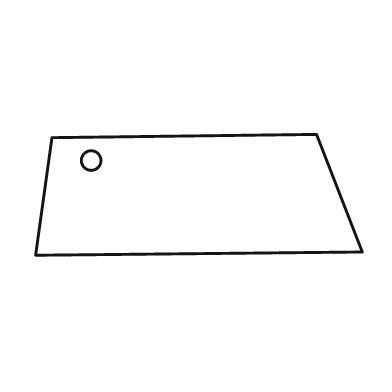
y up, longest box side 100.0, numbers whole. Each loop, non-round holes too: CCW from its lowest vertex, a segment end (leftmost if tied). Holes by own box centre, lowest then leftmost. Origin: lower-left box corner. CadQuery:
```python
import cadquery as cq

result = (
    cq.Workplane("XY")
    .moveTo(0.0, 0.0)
    .lineTo(100.0, 1.0)
    .lineTo(86.0, 37.0)
    .lineTo(5.0, 36.0)
    .close()
    .moveTo(17.0, 29.0)
    .circle(3.0)
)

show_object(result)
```